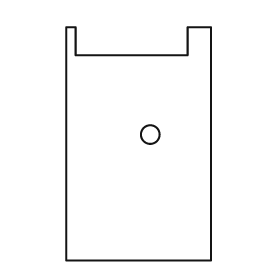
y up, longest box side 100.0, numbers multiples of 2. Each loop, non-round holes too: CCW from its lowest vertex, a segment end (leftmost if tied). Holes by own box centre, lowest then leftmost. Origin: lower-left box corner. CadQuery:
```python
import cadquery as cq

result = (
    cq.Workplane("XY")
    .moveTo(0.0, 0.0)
    .lineTo(62.0, 0.0)
    .lineTo(62.0, 100.0)
    .lineTo(52.0, 100.0)
    .lineTo(52.0, 88.0)
    .lineTo(4.0, 88.0)
    .lineTo(4.0, 100.0)
    .lineTo(0.0, 100.0)
    .close()
    .moveTo(36.0, 54.0)
    .circle(4.0)
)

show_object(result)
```